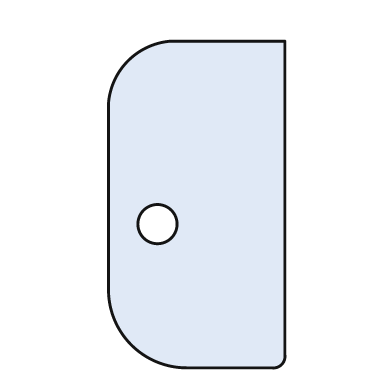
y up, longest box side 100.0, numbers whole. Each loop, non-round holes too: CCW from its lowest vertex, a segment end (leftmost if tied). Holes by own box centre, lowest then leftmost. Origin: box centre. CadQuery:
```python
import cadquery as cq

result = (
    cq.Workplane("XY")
    .moveTo(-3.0, -50.0)
    .lineTo(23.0, -50.0)
    .threePointArc((26.0, -49.0), (27.0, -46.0))
    .lineTo(27.0, 50.0)
    .lineTo(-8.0, 50.0)
    .threePointArc((-21.0, 44.0), (-27.0, 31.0))
    .lineTo(-27.0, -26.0)
    .threePointArc((-20.0, -43.0), (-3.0, -50.0))
    .close()
    .moveTo(-12.0, -6.0)
    .circle(6.0)
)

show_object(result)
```